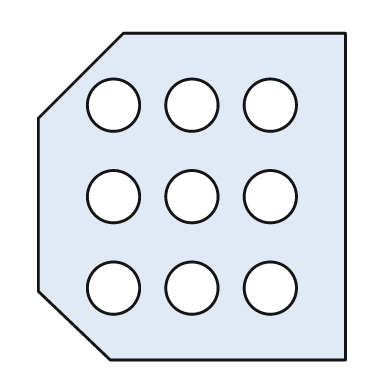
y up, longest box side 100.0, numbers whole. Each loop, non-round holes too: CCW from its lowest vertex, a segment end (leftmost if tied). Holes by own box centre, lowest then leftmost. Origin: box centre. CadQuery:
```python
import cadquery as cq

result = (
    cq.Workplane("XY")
    .moveTo(-25.0, -50.0)
    .lineTo(47.0, -50.0)
    .lineTo(47.0, 50.0)
    .lineTo(-21.0, 50.0)
    .lineTo(-47.0, 24.0)
    .lineTo(-47.0, -29.0)
    .close()
    .moveTo(-24.0, -28.0)
    .circle(8.0)
    .moveTo(0.0, -28.0)
    .circle(8.0)
    .moveTo(24.0, -28.0)
    .circle(8.0)
    .moveTo(-24.0, 0.0)
    .circle(8.0)
    .moveTo(0.0, 0.0)
    .circle(8.0)
    .moveTo(24.0, 0.0)
    .circle(8.0)
    .moveTo(-24.0, 28.0)
    .circle(8.0)
    .moveTo(0.0, 28.0)
    .circle(8.0)
    .moveTo(24.0, 28.0)
    .circle(8.0)
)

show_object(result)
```